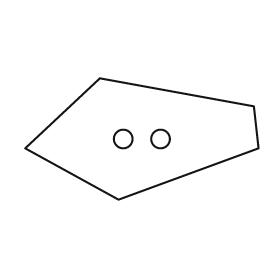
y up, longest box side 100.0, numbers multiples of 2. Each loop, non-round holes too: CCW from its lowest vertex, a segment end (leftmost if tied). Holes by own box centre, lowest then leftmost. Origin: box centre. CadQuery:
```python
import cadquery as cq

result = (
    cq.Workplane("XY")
    .moveTo(-10.0, -26.0)
    .lineTo(50.0, -4.0)
    .lineTo(48.0, 14.0)
    .lineTo(-18.0, 26.0)
    .lineTo(-50.0, -4.0)
    .close()
    .moveTo(-8.0, 0.0)
    .circle(4.0)
    .moveTo(8.0, 0.0)
    .circle(4.0)
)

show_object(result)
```